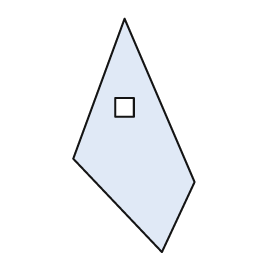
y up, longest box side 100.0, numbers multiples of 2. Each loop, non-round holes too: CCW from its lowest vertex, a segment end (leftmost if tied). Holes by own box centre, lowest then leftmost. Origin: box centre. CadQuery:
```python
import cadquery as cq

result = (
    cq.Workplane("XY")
    .moveTo(12.0, -50.0)
    .lineTo(26.0, -20.0)
    .lineTo(-4.0, 50.0)
    .lineTo(-26.0, -10.0)
    .close()
    .moveTo(-8.0, 8.0)
    .lineTo(0.0, 8.0)
    .lineTo(0.0, 16.0)
    .lineTo(-8.0, 16.0)
    .close()
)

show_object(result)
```